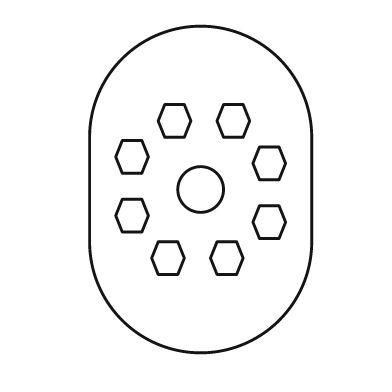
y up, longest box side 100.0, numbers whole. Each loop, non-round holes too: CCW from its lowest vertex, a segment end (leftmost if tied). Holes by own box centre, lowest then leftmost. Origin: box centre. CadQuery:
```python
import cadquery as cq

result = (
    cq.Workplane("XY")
    .moveTo(-34.0, -16.0)
    .threePointArc((0.0, -50.0), (34.0, -16.0))
    .lineTo(34.0, 16.0)
    .threePointArc((0.0, 50.0), (-34.0, 16.0))
    .close()
    .moveTo(-13.0, -26.0)
    .lineTo(-7.0, -26.0)
    .lineTo(-5.0, -21.0)
    .lineTo(-7.0, -16.0)
    .lineTo(-13.0, -16.0)
    .lineTo(-15.0, -21.0)
    .close()
    .moveTo(5.0, -26.0)
    .lineTo(11.0, -26.0)
    .lineTo(13.0, -21.0)
    .lineTo(11.0, -16.0)
    .lineTo(5.0, -16.0)
    .lineTo(3.0, -21.0)
    .close()
    .moveTo(18.0, -15.0)
    .lineTo(24.0, -15.0)
    .lineTo(26.0, -10.0)
    .lineTo(24.0, -5.0)
    .lineTo(18.0, -5.0)
    .lineTo(16.0, -10.0)
    .close()
    .moveTo(-24.0, -13.0)
    .lineTo(-18.0, -13.0)
    .lineTo(-16.0, -8.0)
    .lineTo(-18.0, -3.0)
    .lineTo(-24.0, -3.0)
    .lineTo(-26.0, -8.0)
    .close()
    .moveTo(0.0, 0.0)
    .circle(7.0)
    .moveTo(18.0, 3.0)
    .lineTo(24.0, 3.0)
    .lineTo(26.0, 8.0)
    .lineTo(24.0, 13.0)
    .lineTo(18.0, 13.0)
    .lineTo(16.0, 8.0)
    .close()
    .moveTo(-24.0, 5.0)
    .lineTo(-18.0, 5.0)
    .lineTo(-16.0, 10.0)
    .lineTo(-18.0, 15.0)
    .lineTo(-24.0, 15.0)
    .lineTo(-26.0, 10.0)
    .close()
    .moveTo(-11.0, 16.0)
    .lineTo(-5.0, 16.0)
    .lineTo(-3.0, 21.0)
    .lineTo(-5.0, 26.0)
    .lineTo(-11.0, 26.0)
    .lineTo(-13.0, 21.0)
    .close()
    .moveTo(7.0, 16.0)
    .lineTo(13.0, 16.0)
    .lineTo(15.0, 21.0)
    .lineTo(13.0, 26.0)
    .lineTo(7.0, 26.0)
    .lineTo(5.0, 21.0)
    .close()
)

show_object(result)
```